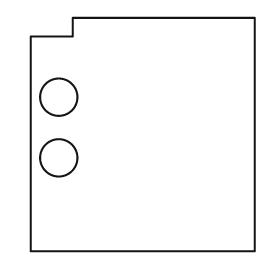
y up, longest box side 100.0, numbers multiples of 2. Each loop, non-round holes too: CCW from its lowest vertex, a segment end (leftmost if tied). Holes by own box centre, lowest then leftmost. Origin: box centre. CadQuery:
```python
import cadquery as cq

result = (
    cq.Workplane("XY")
    .moveTo(-48.0, -50.0)
    .lineTo(48.0, -50.0)
    .lineTo(48.0, 50.0)
    .lineTo(-30.0, 50.0)
    .lineTo(-30.0, 42.0)
    .lineTo(-48.0, 42.0)
    .close()
    .moveTo(-36.0, -10.0)
    .circle(8.0)
    .moveTo(-36.0, 16.0)
    .circle(8.0)
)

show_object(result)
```